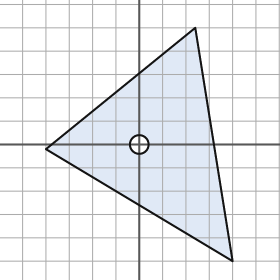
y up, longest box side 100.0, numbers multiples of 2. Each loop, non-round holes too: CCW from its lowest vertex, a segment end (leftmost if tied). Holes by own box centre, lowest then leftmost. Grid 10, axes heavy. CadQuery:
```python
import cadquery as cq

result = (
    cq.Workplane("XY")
    .moveTo(40.0, -50.0)
    .lineTo(24.0, 50.0)
    .lineTo(-40.0, -2.0)
    .close()
    .moveTo(0.0, 0.0)
    .circle(4.0)
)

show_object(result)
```